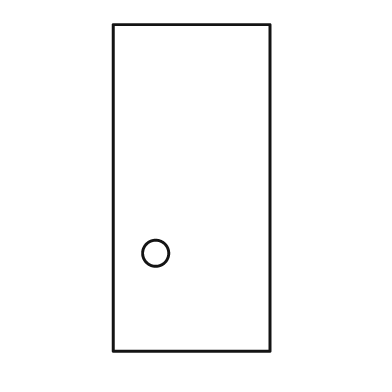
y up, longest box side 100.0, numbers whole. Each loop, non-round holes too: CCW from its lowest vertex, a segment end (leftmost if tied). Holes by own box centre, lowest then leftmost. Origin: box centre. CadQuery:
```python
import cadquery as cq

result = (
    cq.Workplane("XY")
    .moveTo(-24.0, -50.0)
    .lineTo(24.0, -50.0)
    .lineTo(24.0, 50.0)
    .lineTo(-24.0, 50.0)
    .close()
    .moveTo(-11.0, -20.0)
    .circle(4.0)
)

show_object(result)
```